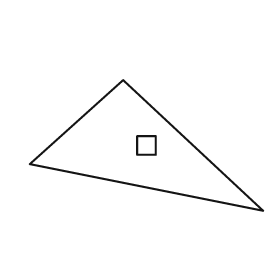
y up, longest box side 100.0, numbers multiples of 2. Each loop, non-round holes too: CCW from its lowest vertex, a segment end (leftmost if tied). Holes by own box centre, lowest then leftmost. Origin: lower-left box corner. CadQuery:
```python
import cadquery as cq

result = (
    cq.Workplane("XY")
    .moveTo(100.0, 0.0)
    .lineTo(40.0, 56.0)
    .lineTo(0.0, 20.0)
    .close()
    .moveTo(46.0, 24.0)
    .lineTo(54.0, 24.0)
    .lineTo(54.0, 32.0)
    .lineTo(46.0, 32.0)
    .close()
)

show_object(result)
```